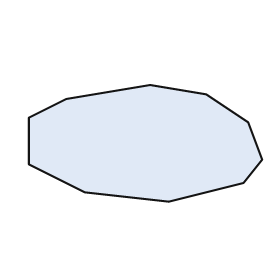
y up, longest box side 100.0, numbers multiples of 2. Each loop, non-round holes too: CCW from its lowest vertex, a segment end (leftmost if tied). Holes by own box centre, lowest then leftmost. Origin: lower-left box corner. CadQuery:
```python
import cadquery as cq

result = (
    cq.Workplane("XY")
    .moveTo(60.0, 0.0)
    .lineTo(92.0, 8.0)
    .lineTo(100.0, 18.0)
    .lineTo(94.0, 34.0)
    .lineTo(76.0, 46.0)
    .lineTo(52.0, 50.0)
    .lineTo(16.0, 44.0)
    .lineTo(0.0, 36.0)
    .lineTo(0.0, 16.0)
    .lineTo(24.0, 4.0)
    .close()
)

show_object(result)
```